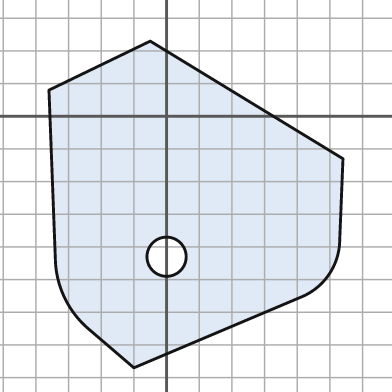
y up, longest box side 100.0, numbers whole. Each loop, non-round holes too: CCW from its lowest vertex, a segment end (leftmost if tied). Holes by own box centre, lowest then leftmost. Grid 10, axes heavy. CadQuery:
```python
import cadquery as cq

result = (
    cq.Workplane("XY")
    .moveTo(-10.0, -77.0)
    .lineTo(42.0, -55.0)
    .threePointArc((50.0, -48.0), (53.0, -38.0))
    .lineTo(54.0, -13.0)
    .lineTo(-5.0, 23.0)
    .lineTo(-36.0, 8.0)
    .lineTo(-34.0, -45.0)
    .threePointArc((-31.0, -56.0), (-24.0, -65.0))
    .close()
    .moveTo(0.0, -43.0)
    .circle(6.0)
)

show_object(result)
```